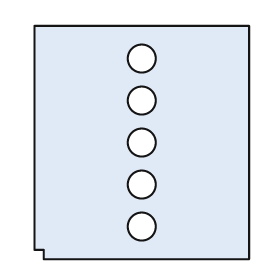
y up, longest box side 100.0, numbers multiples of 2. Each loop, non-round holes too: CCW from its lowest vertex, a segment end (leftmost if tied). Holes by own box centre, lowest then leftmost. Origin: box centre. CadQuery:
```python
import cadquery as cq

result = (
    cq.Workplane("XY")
    .moveTo(-42.0, -50.0)
    .lineTo(46.0, -50.0)
    .lineTo(46.0, 50.0)
    .lineTo(-46.0, 50.0)
    .lineTo(-46.0, -46.0)
    .lineTo(-42.0, -46.0)
    .close()
    .moveTo(0.0, -36.0)
    .circle(6.0)
    .moveTo(0.0, -18.0)
    .circle(6.0)
    .moveTo(0.0, 0.0)
    .circle(6.0)
    .moveTo(0.0, 18.0)
    .circle(6.0)
    .moveTo(0.0, 36.0)
    .circle(6.0)
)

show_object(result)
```